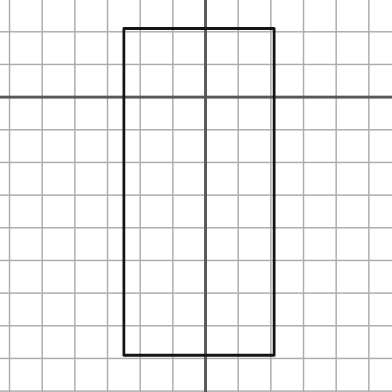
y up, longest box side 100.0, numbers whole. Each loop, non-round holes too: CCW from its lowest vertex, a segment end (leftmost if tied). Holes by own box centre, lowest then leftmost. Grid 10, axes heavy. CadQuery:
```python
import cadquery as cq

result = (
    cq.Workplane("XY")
    .moveTo(-25.0, -79.0)
    .lineTo(21.0, -79.0)
    .lineTo(21.0, 21.0)
    .lineTo(-25.0, 21.0)
    .close()
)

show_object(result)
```